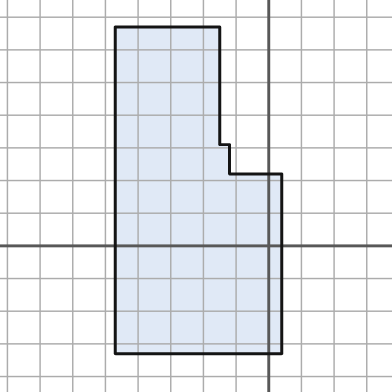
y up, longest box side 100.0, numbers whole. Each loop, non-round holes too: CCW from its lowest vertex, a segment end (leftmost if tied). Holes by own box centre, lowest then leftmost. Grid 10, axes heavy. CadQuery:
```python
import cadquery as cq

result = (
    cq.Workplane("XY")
    .moveTo(-47.0, -33.0)
    .lineTo(4.0, -33.0)
    .lineTo(4.0, 22.0)
    .lineTo(-12.0, 22.0)
    .lineTo(-12.0, 31.0)
    .lineTo(-15.0, 31.0)
    .lineTo(-15.0, 67.0)
    .lineTo(-47.0, 67.0)
    .close()
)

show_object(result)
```